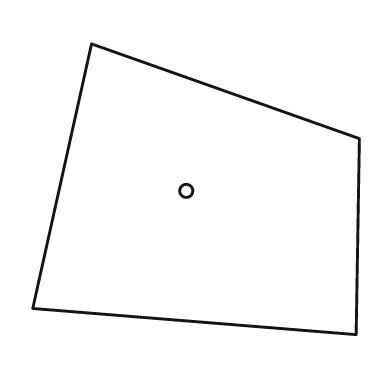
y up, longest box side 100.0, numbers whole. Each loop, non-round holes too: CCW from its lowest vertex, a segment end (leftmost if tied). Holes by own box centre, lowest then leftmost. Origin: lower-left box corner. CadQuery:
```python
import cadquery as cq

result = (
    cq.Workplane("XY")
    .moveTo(99.0, 0.0)
    .lineTo(100.0, 60.0)
    .lineTo(18.0, 89.0)
    .lineTo(0.0, 8.0)
    .close()
    .moveTo(47.0, 44.0)
    .circle(2.0)
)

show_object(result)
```